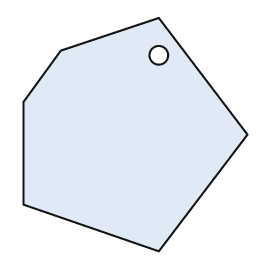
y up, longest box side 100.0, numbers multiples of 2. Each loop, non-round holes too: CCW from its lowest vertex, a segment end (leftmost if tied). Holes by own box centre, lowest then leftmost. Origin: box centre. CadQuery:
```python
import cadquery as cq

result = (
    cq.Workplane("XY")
    .moveTo(10.0, -50.0)
    .lineTo(48.0, 0.0)
    .lineTo(10.0, 50.0)
    .lineTo(-32.0, 36.0)
    .lineTo(-48.0, 14.0)
    .lineTo(-48.0, -30.0)
    .close()
    .moveTo(10.0, 34.0)
    .circle(4.0)
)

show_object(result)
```